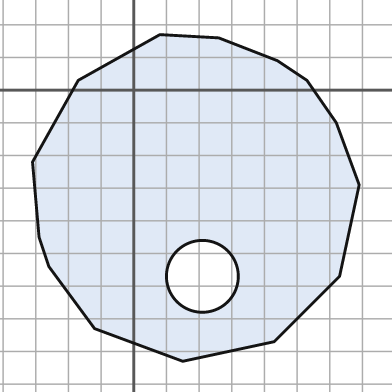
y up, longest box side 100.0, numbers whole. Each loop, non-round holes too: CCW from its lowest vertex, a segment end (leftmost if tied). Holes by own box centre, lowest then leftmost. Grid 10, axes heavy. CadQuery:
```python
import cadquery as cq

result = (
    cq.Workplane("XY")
    .moveTo(15.0, -83.0)
    .lineTo(43.0, -77.0)
    .lineTo(63.0, -57.0)
    .lineTo(69.0, -29.0)
    .lineTo(62.0, -10.0)
    .lineTo(53.0, 3.0)
    .lineTo(44.0, 9.0)
    .lineTo(26.0, 16.0)
    .lineTo(8.0, 17.0)
    .lineTo(-17.0, 3.0)
    .lineTo(-31.0, -22.0)
    .lineTo(-29.0, -45.0)
    .lineTo(-26.0, -54.0)
    .lineTo(-12.0, -73.0)
    .close()
    .moveTo(21.0, -57.0)
    .circle(11.0)
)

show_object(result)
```